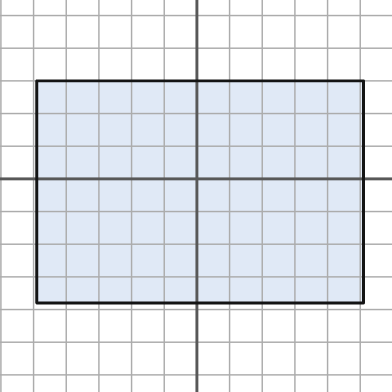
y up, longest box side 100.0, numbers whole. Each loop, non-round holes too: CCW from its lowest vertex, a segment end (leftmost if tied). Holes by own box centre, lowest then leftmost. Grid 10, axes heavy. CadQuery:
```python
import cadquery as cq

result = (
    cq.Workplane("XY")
    .moveTo(-49.0, -38.0)
    .lineTo(51.0, -38.0)
    .lineTo(51.0, 30.0)
    .lineTo(-49.0, 30.0)
    .close()
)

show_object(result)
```